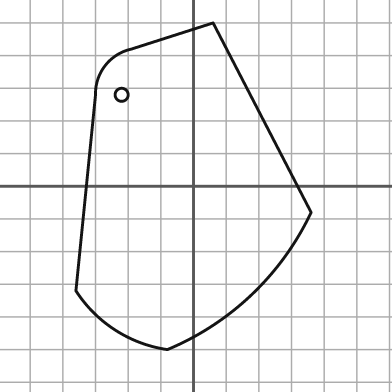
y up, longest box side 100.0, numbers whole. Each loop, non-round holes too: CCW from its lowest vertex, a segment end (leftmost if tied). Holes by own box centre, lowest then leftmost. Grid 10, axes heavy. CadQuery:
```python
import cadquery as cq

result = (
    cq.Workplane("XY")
    .moveTo(-8.0, -50.0)
    .threePointArc((18.0, -33.0), (36.0, -8.0))
    .lineTo(6.0, 50.0)
    .lineTo(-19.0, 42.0)
    .threePointArc((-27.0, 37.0), (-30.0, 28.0))
    .lineTo(-36.0, -32.0)
    .threePointArc((-24.0, -44.0), (-8.0, -50.0))
    .close()
    .moveTo(-22.0, 28.0)
    .circle(2.0)
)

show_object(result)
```